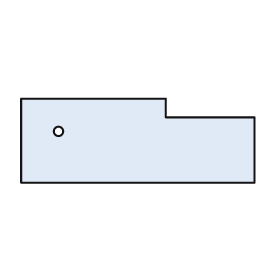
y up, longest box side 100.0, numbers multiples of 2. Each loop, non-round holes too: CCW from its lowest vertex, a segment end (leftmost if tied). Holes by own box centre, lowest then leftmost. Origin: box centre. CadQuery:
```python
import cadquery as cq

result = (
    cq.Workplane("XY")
    .moveTo(-50.0, -18.0)
    .lineTo(50.0, -18.0)
    .lineTo(50.0, 10.0)
    .lineTo(12.0, 10.0)
    .lineTo(12.0, 18.0)
    .lineTo(-50.0, 18.0)
    .close()
    .moveTo(-34.0, 4.0)
    .circle(2.0)
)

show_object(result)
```